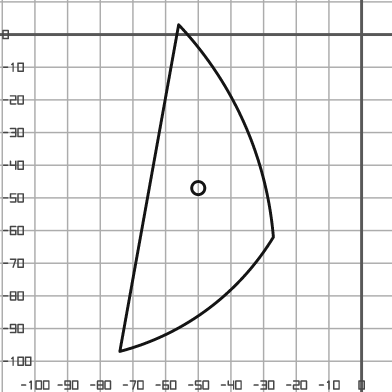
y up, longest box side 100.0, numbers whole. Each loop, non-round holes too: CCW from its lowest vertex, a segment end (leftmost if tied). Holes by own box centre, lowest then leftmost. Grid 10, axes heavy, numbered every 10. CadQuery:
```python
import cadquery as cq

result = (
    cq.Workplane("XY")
    .moveTo(-74.0, -97.0)
    .threePointArc((-47.0, -84.0), (-27.0, -62.0))
    .threePointArc((-36.0, -27.0), (-56.0, 3.0))
    .close()
    .moveTo(-50.0, -47.0)
    .circle(2.0)
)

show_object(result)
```